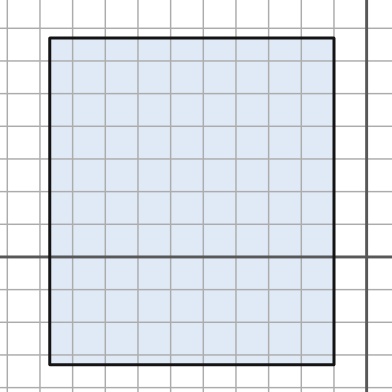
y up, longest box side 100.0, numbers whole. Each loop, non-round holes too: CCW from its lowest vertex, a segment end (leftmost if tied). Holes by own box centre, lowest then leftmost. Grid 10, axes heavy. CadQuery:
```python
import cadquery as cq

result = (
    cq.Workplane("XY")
    .moveTo(-97.0, -33.0)
    .lineTo(-10.0, -33.0)
    .lineTo(-10.0, 67.0)
    .lineTo(-97.0, 67.0)
    .close()
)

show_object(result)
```